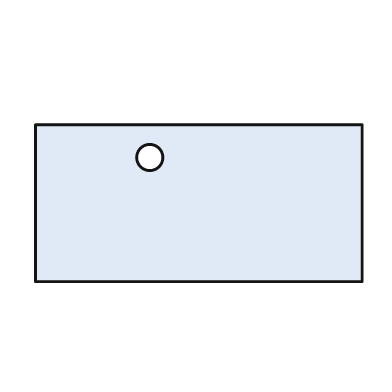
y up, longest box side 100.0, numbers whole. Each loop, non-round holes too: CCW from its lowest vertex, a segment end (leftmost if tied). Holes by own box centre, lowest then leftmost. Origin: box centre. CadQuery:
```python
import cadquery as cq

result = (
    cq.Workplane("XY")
    .moveTo(-50.0, -24.0)
    .lineTo(50.0, -24.0)
    .lineTo(50.0, 24.0)
    .lineTo(-50.0, 24.0)
    .close()
    .moveTo(-15.0, 14.0)
    .circle(4.0)
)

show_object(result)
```